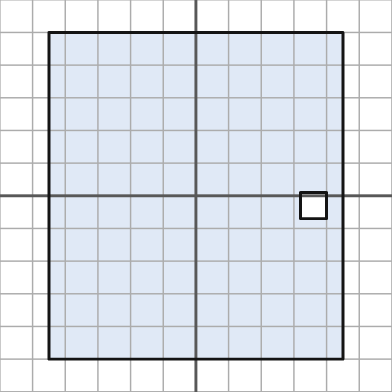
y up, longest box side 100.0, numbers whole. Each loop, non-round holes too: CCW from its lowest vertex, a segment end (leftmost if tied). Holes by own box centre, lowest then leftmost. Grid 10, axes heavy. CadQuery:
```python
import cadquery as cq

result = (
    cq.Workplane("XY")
    .moveTo(-45.0, -50.0)
    .lineTo(45.0, -50.0)
    .lineTo(45.0, 50.0)
    .lineTo(-45.0, 50.0)
    .close()
    .moveTo(32.0, -7.0)
    .lineTo(40.0, -7.0)
    .lineTo(40.0, 1.0)
    .lineTo(32.0, 1.0)
    .close()
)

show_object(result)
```